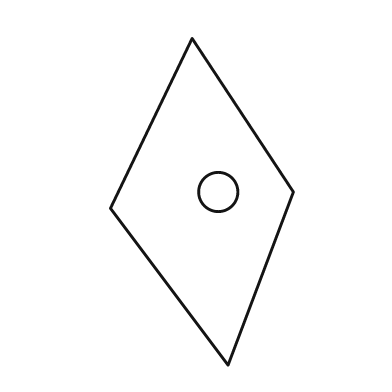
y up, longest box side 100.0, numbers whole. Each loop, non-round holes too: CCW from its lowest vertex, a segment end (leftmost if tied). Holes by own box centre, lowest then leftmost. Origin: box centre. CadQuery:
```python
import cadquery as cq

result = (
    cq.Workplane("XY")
    .moveTo(8.0, -50.0)
    .lineTo(28.0, 3.0)
    .lineTo(-3.0, 50.0)
    .lineTo(-28.0, -2.0)
    .close()
    .moveTo(5.0, 3.0)
    .circle(6.0)
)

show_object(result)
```